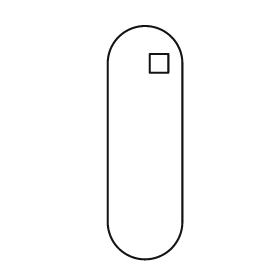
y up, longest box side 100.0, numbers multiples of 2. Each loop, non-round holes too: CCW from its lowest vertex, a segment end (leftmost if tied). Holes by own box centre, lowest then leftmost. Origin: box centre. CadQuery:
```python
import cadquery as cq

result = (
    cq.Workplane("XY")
    .moveTo(-16.0, -34.0)
    .threePointArc((0.0, -50.0), (16.0, -34.0))
    .lineTo(16.0, 34.0)
    .threePointArc((0.0, 50.0), (-16.0, 34.0))
    .close()
    .moveTo(2.0, 30.0)
    .lineTo(10.0, 30.0)
    .lineTo(10.0, 38.0)
    .lineTo(2.0, 38.0)
    .close()
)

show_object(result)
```